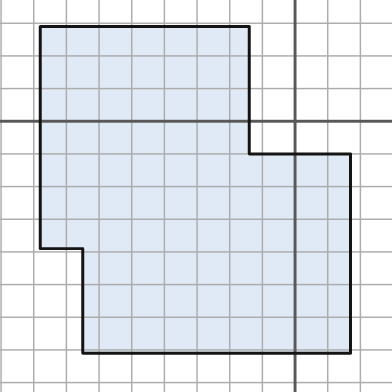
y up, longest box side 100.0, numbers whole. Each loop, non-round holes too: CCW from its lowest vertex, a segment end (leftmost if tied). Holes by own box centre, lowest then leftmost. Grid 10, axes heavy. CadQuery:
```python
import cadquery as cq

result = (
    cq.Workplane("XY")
    .moveTo(-65.0, -71.0)
    .lineTo(17.0, -71.0)
    .lineTo(17.0, -10.0)
    .lineTo(-14.0, -10.0)
    .lineTo(-14.0, 29.0)
    .lineTo(-78.0, 29.0)
    .lineTo(-78.0, -39.0)
    .lineTo(-65.0, -39.0)
    .close()
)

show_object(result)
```